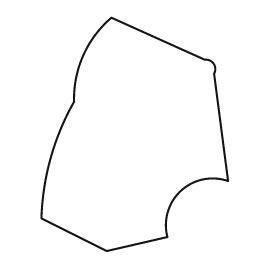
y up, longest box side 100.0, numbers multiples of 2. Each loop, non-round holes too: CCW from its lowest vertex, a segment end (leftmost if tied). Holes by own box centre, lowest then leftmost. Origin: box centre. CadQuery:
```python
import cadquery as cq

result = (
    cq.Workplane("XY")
    .moveTo(-12.0, -50.0)
    .lineTo(14.0, -44.0)
    .threePointArc((20.0, -24.0), (40.0, -20.0))
    .lineTo(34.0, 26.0)
    .threePointArc((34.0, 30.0), (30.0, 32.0))
    .lineTo(-10.0, 50.0)
    .threePointArc((-22.0, 34.0), (-26.0, 14.0))
    .threePointArc((-36.0, -10.0), (-40.0, -36.0))
    .close()
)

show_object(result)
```